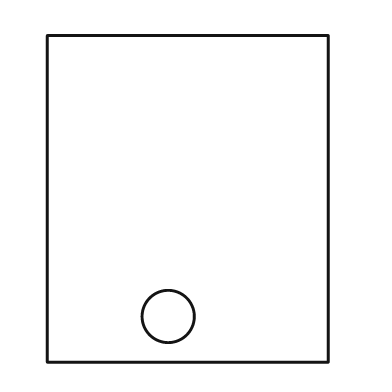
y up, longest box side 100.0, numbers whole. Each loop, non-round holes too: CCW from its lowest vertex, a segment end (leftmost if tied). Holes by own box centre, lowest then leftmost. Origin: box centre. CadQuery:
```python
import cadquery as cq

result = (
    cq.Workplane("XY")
    .moveTo(-43.0, -50.0)
    .lineTo(43.0, -50.0)
    .lineTo(43.0, 50.0)
    .lineTo(-43.0, 50.0)
    .close()
    .moveTo(-6.0, -36.0)
    .circle(8.0)
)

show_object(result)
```